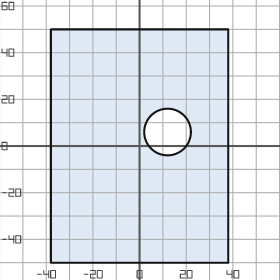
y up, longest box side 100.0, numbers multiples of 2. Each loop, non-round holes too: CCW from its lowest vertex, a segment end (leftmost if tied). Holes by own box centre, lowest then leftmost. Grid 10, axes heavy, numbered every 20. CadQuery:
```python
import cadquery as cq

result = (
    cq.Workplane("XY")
    .moveTo(-38.0, -50.0)
    .lineTo(38.0, -50.0)
    .lineTo(38.0, 50.0)
    .lineTo(-38.0, 50.0)
    .close()
    .moveTo(12.0, 6.0)
    .circle(10.0)
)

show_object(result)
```